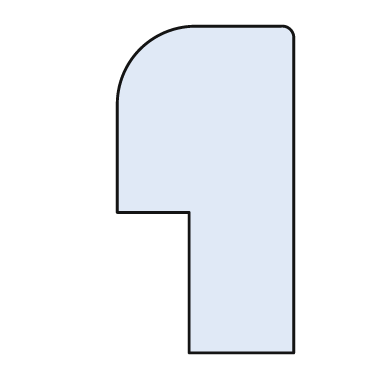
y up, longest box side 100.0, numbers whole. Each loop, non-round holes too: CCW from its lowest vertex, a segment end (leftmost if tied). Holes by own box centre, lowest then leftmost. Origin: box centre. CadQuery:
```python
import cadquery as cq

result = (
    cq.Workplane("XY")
    .moveTo(-5.0, -50.0)
    .lineTo(27.0, -50.0)
    .lineTo(27.0, 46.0)
    .threePointArc((26.0, 49.0), (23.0, 50.0))
    .lineTo(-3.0, 50.0)
    .threePointArc((-20.0, 43.0), (-27.0, 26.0))
    .lineTo(-27.0, -7.0)
    .lineTo(-5.0, -7.0)
    .close()
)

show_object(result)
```